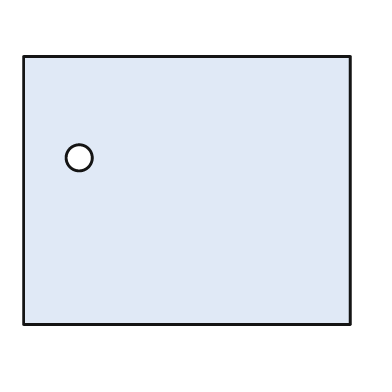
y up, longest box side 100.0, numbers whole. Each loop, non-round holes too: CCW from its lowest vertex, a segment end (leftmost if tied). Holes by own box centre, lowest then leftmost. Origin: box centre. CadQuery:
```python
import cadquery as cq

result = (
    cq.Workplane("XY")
    .moveTo(-50.0, -41.0)
    .lineTo(50.0, -41.0)
    .lineTo(50.0, 41.0)
    .lineTo(-50.0, 41.0)
    .close()
    .moveTo(-33.0, 10.0)
    .circle(4.0)
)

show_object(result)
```